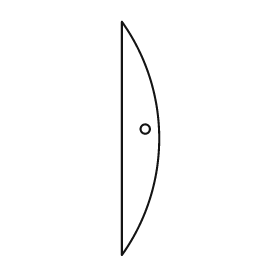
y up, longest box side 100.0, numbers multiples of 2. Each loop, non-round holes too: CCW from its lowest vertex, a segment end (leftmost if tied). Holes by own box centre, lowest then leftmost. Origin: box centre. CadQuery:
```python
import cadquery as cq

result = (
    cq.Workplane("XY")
    .moveTo(-8.0, -50.0)
    .threePointArc((8.0, 0.0), (-8.0, 50.0))
    .close()
    .moveTo(2.0, 4.0)
    .circle(2.0)
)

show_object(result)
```